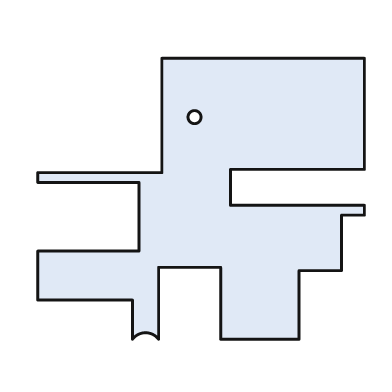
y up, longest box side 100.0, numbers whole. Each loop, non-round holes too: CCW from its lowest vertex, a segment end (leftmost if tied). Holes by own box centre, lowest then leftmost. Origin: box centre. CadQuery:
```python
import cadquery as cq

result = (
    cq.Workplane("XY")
    .moveTo(-21.0, -43.0)
    .threePointArc((-17.0, -41.0), (-13.0, -43.0))
    .lineTo(-13.0, -21.0)
    .lineTo(6.0, -21.0)
    .lineTo(6.0, -43.0)
    .lineTo(30.0, -43.0)
    .lineTo(30.0, -22.0)
    .lineTo(43.0, -22.0)
    .lineTo(43.0, -5.0)
    .lineTo(50.0, -5.0)
    .lineTo(50.0, -2.0)
    .lineTo(9.0, -2.0)
    .lineTo(9.0, 9.0)
    .lineTo(50.0, 9.0)
    .lineTo(50.0, 43.0)
    .lineTo(-12.0, 43.0)
    .lineTo(-12.0, 8.0)
    .lineTo(-50.0, 8.0)
    .lineTo(-50.0, 5.0)
    .lineTo(-19.0, 5.0)
    .lineTo(-19.0, -16.0)
    .lineTo(-50.0, -16.0)
    .lineTo(-50.0, -31.0)
    .lineTo(-21.0, -31.0)
    .close()
    .moveTo(-2.0, 25.0)
    .circle(2.0)
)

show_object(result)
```